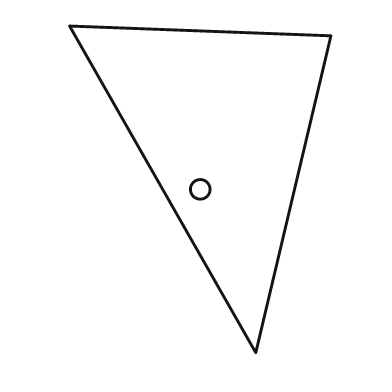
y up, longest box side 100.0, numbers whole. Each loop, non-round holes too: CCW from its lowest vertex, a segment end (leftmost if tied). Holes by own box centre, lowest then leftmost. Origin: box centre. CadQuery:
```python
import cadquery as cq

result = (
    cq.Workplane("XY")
    .moveTo(17.0, -50.0)
    .lineTo(40.0, 47.0)
    .lineTo(-40.0, 50.0)
    .close()
    .moveTo(0.0, 0.0)
    .circle(3.0)
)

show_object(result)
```